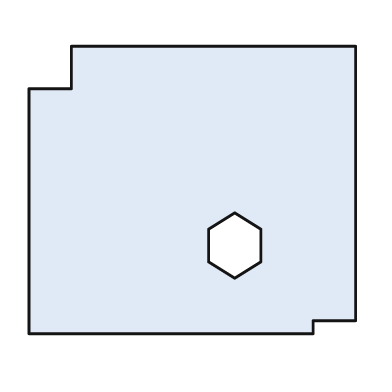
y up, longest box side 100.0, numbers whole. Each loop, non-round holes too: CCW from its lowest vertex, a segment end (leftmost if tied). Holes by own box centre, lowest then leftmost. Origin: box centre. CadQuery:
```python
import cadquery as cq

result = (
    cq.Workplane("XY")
    .moveTo(-50.0, -44.0)
    .lineTo(37.0, -44.0)
    .lineTo(37.0, -40.0)
    .lineTo(50.0, -40.0)
    .lineTo(50.0, 44.0)
    .lineTo(-37.0, 44.0)
    .lineTo(-37.0, 31.0)
    .lineTo(-50.0, 31.0)
    .close()
    .moveTo(13.0, -27.0)
    .lineTo(21.0, -22.0)
    .lineTo(21.0, -12.0)
    .lineTo(13.0, -7.0)
    .lineTo(5.0, -12.0)
    .lineTo(5.0, -22.0)
    .close()
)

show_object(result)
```